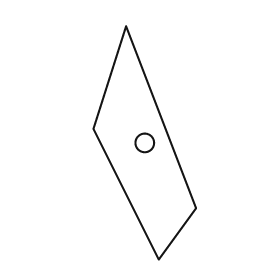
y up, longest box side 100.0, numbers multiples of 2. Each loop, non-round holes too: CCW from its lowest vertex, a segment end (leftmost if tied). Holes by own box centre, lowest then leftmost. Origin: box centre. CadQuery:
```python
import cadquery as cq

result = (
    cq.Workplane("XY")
    .moveTo(6.0, -50.0)
    .lineTo(22.0, -28.0)
    .lineTo(-8.0, 50.0)
    .lineTo(-22.0, 6.0)
    .close()
    .moveTo(0.0, 0.0)
    .circle(4.0)
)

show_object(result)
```